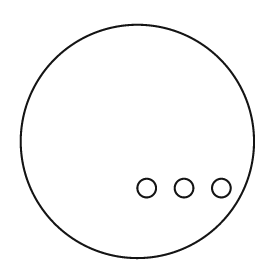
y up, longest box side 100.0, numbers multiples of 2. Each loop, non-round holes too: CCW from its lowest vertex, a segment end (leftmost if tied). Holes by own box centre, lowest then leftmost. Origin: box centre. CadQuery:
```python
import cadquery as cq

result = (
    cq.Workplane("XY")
    .moveTo(0.0, 0.0)
    .circle(50.0)
    .moveTo(4.0, -20.0)
    .circle(4.0)
    .moveTo(20.0, -20.0)
    .circle(4.0)
    .moveTo(36.0, -20.0)
    .circle(4.0)
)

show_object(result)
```